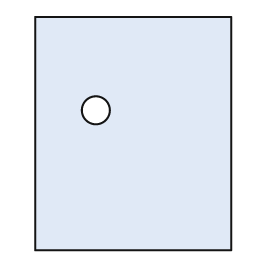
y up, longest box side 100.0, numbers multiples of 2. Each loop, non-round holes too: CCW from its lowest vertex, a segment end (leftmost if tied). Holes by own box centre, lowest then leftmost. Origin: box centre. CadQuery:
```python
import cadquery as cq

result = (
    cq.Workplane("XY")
    .moveTo(-42.0, -50.0)
    .lineTo(42.0, -50.0)
    .lineTo(42.0, 50.0)
    .lineTo(-42.0, 50.0)
    .close()
    .moveTo(-16.0, 10.0)
    .circle(6.0)
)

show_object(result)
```